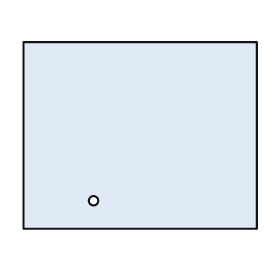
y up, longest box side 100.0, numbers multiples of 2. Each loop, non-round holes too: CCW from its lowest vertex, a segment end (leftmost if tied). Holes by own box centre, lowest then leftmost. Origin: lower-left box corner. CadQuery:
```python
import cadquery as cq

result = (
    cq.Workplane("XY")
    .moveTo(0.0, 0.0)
    .lineTo(100.0, 0.0)
    .lineTo(100.0, 80.0)
    .lineTo(0.0, 80.0)
    .close()
    .moveTo(30.0, 12.0)
    .circle(2.0)
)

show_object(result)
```